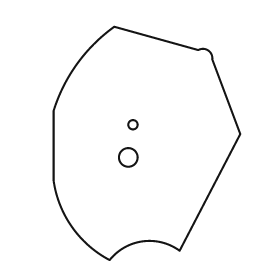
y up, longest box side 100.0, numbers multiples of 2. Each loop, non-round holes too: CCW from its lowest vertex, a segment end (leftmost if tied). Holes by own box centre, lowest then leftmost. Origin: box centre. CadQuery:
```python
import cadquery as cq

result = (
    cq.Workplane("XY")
    .moveTo(-16.0, -50.0)
    .threePointArc((-2.0, -42.0), (14.0, -46.0))
    .lineTo(40.0, 4.0)
    .lineTo(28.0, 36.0)
    .threePointArc((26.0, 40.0), (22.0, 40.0))
    .lineTo(-14.0, 50.0)
    .threePointArc((-30.0, 34.0), (-40.0, 14.0))
    .lineTo(-40.0, -16.0)
    .threePointArc((-32.0, -36.0), (-16.0, -50.0))
    .close()
    .moveTo(-8.0, -6.0)
    .circle(4.0)
    .moveTo(-6.0, 8.0)
    .circle(2.0)
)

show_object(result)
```